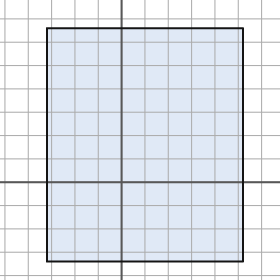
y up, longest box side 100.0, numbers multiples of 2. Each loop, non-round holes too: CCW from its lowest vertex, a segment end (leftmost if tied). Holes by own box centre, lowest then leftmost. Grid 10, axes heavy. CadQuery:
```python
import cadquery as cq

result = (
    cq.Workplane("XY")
    .moveTo(-32.0, -34.0)
    .lineTo(52.0, -34.0)
    .lineTo(52.0, 66.0)
    .lineTo(-32.0, 66.0)
    .close()
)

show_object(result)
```